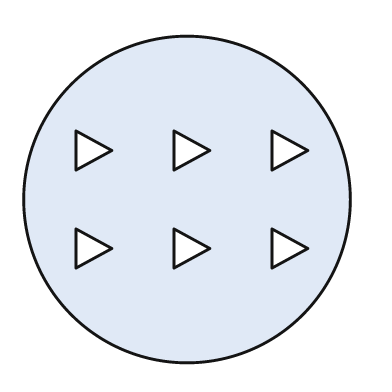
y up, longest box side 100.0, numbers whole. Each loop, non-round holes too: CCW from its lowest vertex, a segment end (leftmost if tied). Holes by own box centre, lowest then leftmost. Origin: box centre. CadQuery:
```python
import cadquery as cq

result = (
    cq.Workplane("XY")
    .moveTo(0.0, 0.0)
    .circle(50.0)
    .moveTo(-34.0, -21.0)
    .lineTo(-23.0, -15.0)
    .lineTo(-34.0, -9.0)
    .close()
    .moveTo(-4.0, -21.0)
    .lineTo(7.0, -15.0)
    .lineTo(-4.0, -9.0)
    .close()
    .moveTo(26.0, -21.0)
    .lineTo(37.0, -15.0)
    .lineTo(26.0, -9.0)
    .close()
    .moveTo(-34.0, 9.0)
    .lineTo(-23.0, 15.0)
    .lineTo(-34.0, 21.0)
    .close()
    .moveTo(-4.0, 9.0)
    .lineTo(7.0, 15.0)
    .lineTo(-4.0, 21.0)
    .close()
    .moveTo(26.0, 9.0)
    .lineTo(37.0, 15.0)
    .lineTo(26.0, 21.0)
    .close()
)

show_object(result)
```